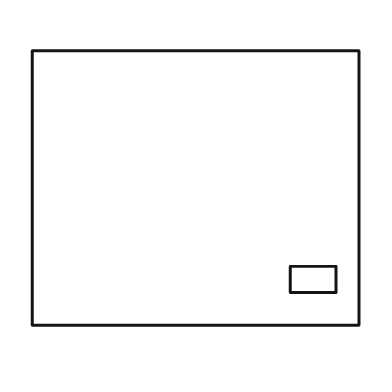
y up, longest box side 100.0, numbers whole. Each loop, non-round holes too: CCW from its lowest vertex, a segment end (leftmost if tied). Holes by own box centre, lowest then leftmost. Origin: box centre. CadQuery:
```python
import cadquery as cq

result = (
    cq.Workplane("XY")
    .moveTo(-50.0, -42.0)
    .lineTo(50.0, -42.0)
    .lineTo(50.0, 42.0)
    .lineTo(-50.0, 42.0)
    .close()
    .moveTo(29.0, -32.0)
    .lineTo(43.0, -32.0)
    .lineTo(43.0, -24.0)
    .lineTo(29.0, -24.0)
    .close()
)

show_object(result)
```